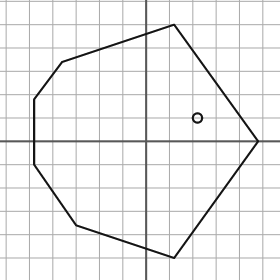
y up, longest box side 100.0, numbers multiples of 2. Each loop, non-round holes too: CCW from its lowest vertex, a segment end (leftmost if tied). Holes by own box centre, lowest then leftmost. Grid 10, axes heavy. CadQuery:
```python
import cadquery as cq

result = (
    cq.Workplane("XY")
    .moveTo(12.0, -50.0)
    .lineTo(48.0, 0.0)
    .lineTo(12.0, 50.0)
    .lineTo(-36.0, 34.0)
    .lineTo(-48.0, 18.0)
    .lineTo(-48.0, -10.0)
    .lineTo(-30.0, -36.0)
    .close()
    .moveTo(22.0, 10.0)
    .circle(2.0)
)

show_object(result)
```